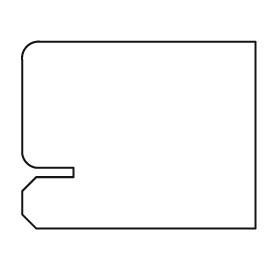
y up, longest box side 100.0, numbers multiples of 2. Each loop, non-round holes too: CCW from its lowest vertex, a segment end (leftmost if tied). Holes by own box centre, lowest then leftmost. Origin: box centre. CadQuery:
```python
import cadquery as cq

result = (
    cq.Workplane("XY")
    .moveTo(-44.0, -40.0)
    .lineTo(50.0, -40.0)
    .lineTo(50.0, 40.0)
    .lineTo(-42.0, 40.0)
    .threePointArc((-48.0, 38.0), (-50.0, 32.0))
    .lineTo(-50.0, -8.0)
    .threePointArc((-48.0, -12.0), (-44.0, -14.0))
    .lineTo(-28.0, -14.0)
    .lineTo(-28.0, -18.0)
    .lineTo(-44.0, -18.0)
    .lineTo(-50.0, -24.0)
    .lineTo(-50.0, -34.0)
    .close()
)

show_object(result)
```